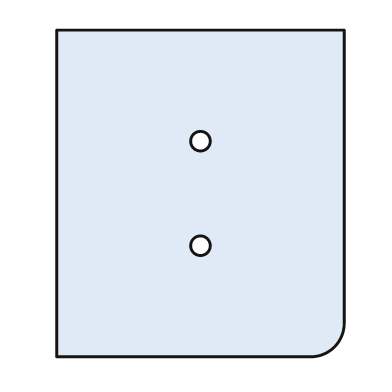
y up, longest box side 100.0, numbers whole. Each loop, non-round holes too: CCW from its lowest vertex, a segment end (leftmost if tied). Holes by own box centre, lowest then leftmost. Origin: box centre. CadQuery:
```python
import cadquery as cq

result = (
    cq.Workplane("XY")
    .moveTo(-44.0, -50.0)
    .lineTo(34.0, -50.0)
    .threePointArc((41.0, -47.0), (44.0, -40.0))
    .lineTo(44.0, 50.0)
    .lineTo(-44.0, 50.0)
    .close()
    .moveTo(0.0, -16.0)
    .circle(3.0)
    .moveTo(0.0, 16.0)
    .circle(3.0)
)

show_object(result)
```